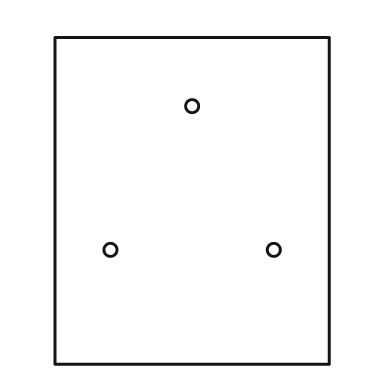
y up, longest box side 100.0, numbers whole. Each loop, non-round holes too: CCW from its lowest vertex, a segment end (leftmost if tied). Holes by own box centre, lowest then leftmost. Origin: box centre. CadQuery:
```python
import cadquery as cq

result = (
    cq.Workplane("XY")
    .moveTo(-42.0, -50.0)
    .lineTo(42.0, -50.0)
    .lineTo(42.0, 50.0)
    .lineTo(-42.0, 50.0)
    .close()
    .moveTo(-25.0, -15.0)
    .circle(2.0)
    .moveTo(25.0, -15.0)
    .circle(2.0)
    .moveTo(0.0, 29.0)
    .circle(2.0)
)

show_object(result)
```